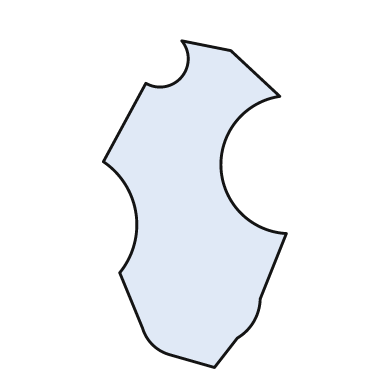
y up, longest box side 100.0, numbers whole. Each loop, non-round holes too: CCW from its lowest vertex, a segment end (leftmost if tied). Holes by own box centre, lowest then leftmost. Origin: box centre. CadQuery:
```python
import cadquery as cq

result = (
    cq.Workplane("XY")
    .moveTo(6.0, -50.0)
    .lineTo(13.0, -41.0)
    .threePointArc((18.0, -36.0), (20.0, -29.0))
    .lineTo(28.0, -9.0)
    .threePointArc((8.0, 11.0), (26.0, 33.0))
    .lineTo(11.0, 47.0)
    .lineTo(-4.0, 50.0)
    .threePointArc((-4.0, 39.0), (-15.0, 37.0))
    .lineTo(-28.0, 13.0)
    .threePointArc((-18.0, -3.0), (-23.0, -21.0))
    .lineTo(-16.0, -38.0)
    .threePointArc((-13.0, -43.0), (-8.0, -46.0))
    .close()
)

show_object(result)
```